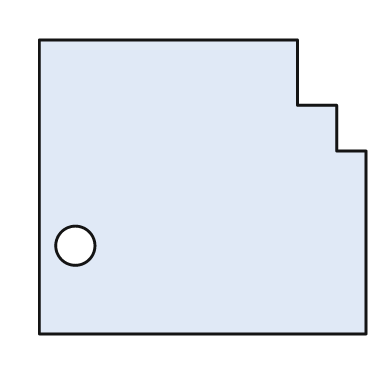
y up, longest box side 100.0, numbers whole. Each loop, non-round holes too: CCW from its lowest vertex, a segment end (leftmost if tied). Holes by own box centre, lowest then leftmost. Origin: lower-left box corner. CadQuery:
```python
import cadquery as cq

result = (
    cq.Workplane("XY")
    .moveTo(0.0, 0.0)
    .lineTo(100.0, 0.0)
    .lineTo(100.0, 56.0)
    .lineTo(91.0, 56.0)
    .lineTo(91.0, 70.0)
    .lineTo(79.0, 70.0)
    .lineTo(79.0, 90.0)
    .lineTo(0.0, 90.0)
    .close()
    .moveTo(11.0, 27.0)
    .circle(6.0)
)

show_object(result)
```